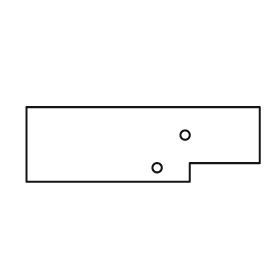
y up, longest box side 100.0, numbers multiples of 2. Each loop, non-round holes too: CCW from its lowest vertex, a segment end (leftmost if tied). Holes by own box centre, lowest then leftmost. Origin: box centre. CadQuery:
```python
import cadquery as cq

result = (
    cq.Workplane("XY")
    .moveTo(-50.0, -16.0)
    .lineTo(20.0, -16.0)
    .lineTo(20.0, -8.0)
    .lineTo(50.0, -8.0)
    .lineTo(50.0, 16.0)
    .lineTo(-50.0, 16.0)
    .close()
    .moveTo(6.0, -10.0)
    .circle(2.0)
    .moveTo(18.0, 4.0)
    .circle(2.0)
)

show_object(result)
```